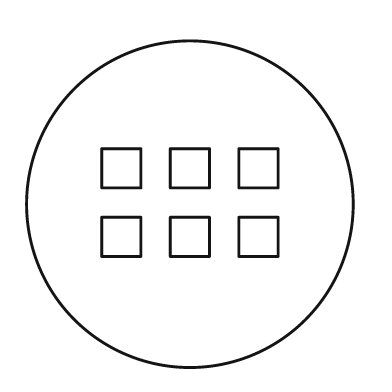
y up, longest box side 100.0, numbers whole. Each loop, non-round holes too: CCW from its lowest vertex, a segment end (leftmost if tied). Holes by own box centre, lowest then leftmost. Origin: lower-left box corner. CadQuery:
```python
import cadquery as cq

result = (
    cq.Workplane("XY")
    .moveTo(50.0, 50.0)
    .circle(50.0)
    .moveTo(23.0, 34.0)
    .lineTo(35.0, 34.0)
    .lineTo(35.0, 46.0)
    .lineTo(23.0, 46.0)
    .close()
    .moveTo(44.0, 34.0)
    .lineTo(56.0, 34.0)
    .lineTo(56.0, 46.0)
    .lineTo(44.0, 46.0)
    .close()
    .moveTo(65.0, 34.0)
    .lineTo(77.0, 34.0)
    .lineTo(77.0, 46.0)
    .lineTo(65.0, 46.0)
    .close()
    .moveTo(23.0, 55.0)
    .lineTo(35.0, 55.0)
    .lineTo(35.0, 67.0)
    .lineTo(23.0, 67.0)
    .close()
    .moveTo(44.0, 55.0)
    .lineTo(56.0, 55.0)
    .lineTo(56.0, 67.0)
    .lineTo(44.0, 67.0)
    .close()
    .moveTo(65.0, 55.0)
    .lineTo(77.0, 55.0)
    .lineTo(77.0, 67.0)
    .lineTo(65.0, 67.0)
    .close()
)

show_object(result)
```